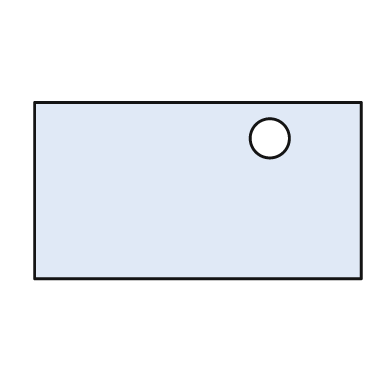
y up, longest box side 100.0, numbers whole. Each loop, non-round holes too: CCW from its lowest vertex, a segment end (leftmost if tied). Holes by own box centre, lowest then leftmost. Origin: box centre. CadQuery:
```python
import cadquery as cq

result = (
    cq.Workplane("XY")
    .moveTo(-50.0, -27.0)
    .lineTo(50.0, -27.0)
    .lineTo(50.0, 27.0)
    .lineTo(-50.0, 27.0)
    .close()
    .moveTo(22.0, 16.0)
    .circle(6.0)
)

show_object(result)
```